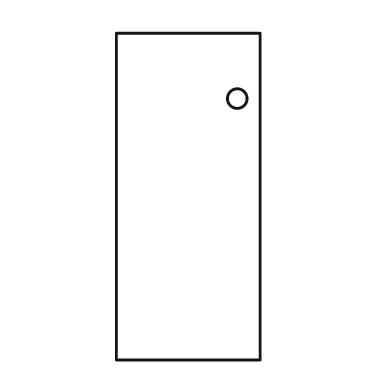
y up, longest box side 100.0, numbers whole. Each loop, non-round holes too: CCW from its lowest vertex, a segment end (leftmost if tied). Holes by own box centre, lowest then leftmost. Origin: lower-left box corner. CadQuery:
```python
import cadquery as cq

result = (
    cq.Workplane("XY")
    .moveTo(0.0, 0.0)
    .lineTo(44.0, 0.0)
    .lineTo(44.0, 100.0)
    .lineTo(0.0, 100.0)
    .close()
    .moveTo(37.0, 80.0)
    .circle(3.0)
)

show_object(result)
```